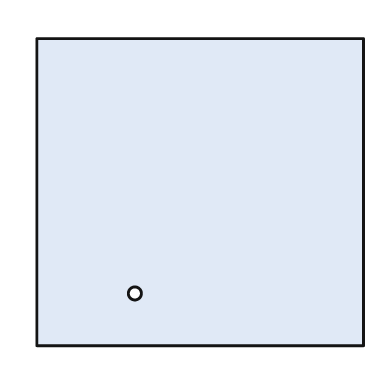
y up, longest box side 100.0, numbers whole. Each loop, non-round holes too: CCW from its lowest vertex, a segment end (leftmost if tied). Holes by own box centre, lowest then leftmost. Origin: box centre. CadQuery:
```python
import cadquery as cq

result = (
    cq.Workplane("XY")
    .moveTo(-50.0, -47.0)
    .lineTo(50.0, -47.0)
    .lineTo(50.0, 47.0)
    .lineTo(-50.0, 47.0)
    .close()
    .moveTo(-20.0, -31.0)
    .circle(2.0)
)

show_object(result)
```